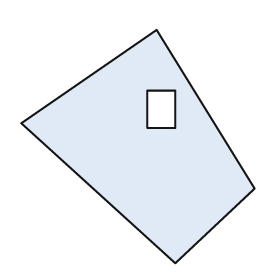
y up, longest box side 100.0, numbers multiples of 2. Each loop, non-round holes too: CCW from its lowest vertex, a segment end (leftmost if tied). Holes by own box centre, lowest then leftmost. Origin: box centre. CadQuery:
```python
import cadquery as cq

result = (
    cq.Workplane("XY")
    .moveTo(16.0, -50.0)
    .lineTo(50.0, -18.0)
    .lineTo(8.0, 50.0)
    .lineTo(-50.0, 10.0)
    .close()
    .moveTo(4.0, 8.0)
    .lineTo(16.0, 8.0)
    .lineTo(16.0, 24.0)
    .lineTo(4.0, 24.0)
    .close()
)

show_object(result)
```